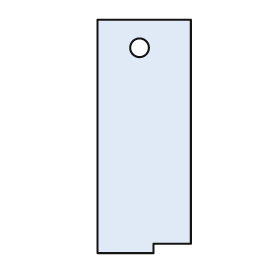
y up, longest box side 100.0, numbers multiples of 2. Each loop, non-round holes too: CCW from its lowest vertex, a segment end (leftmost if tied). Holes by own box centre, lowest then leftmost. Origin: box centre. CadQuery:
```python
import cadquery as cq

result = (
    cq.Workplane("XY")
    .moveTo(-20.0, -50.0)
    .lineTo(4.0, -50.0)
    .lineTo(4.0, -46.0)
    .lineTo(20.0, -46.0)
    .lineTo(20.0, 50.0)
    .lineTo(-20.0, 50.0)
    .close()
    .moveTo(-2.0, 38.0)
    .circle(4.0)
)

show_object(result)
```